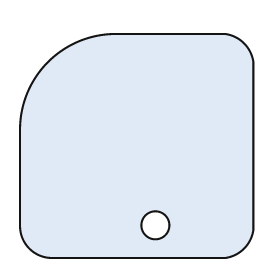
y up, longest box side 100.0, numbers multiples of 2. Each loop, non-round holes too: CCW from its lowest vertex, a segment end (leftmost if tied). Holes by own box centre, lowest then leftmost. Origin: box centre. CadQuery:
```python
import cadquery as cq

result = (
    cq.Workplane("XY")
    .moveTo(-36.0, -48.0)
    .lineTo(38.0, -48.0)
    .threePointArc((46.0, -44.0), (50.0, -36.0))
    .lineTo(50.0, 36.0)
    .threePointArc((46.0, 44.0), (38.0, 48.0))
    .lineTo(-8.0, 48.0)
    .threePointArc((-38.0, 36.0), (-50.0, 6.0))
    .lineTo(-50.0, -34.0)
    .threePointArc((-46.0, -44.0), (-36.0, -48.0))
    .close()
    .moveTo(8.0, -34.0)
    .circle(6.0)
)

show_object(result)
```